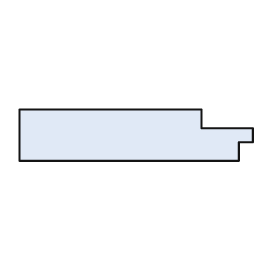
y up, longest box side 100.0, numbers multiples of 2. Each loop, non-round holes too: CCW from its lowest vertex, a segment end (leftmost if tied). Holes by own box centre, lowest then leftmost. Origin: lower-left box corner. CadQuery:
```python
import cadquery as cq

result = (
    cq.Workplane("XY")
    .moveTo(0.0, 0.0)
    .lineTo(94.0, 0.0)
    .lineTo(94.0, 8.0)
    .lineTo(100.0, 8.0)
    .lineTo(100.0, 14.0)
    .lineTo(78.0, 14.0)
    .lineTo(78.0, 22.0)
    .lineTo(0.0, 22.0)
    .close()
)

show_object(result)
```